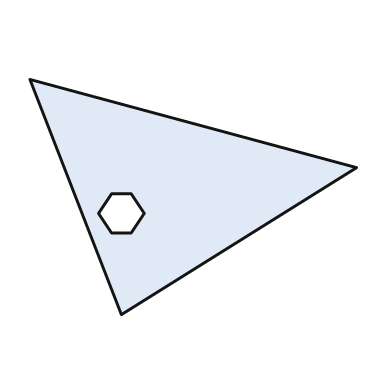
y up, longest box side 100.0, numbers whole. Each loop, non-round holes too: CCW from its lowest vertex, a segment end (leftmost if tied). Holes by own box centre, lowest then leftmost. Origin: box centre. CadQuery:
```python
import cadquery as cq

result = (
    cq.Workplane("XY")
    .moveTo(-22.0, -36.0)
    .lineTo(50.0, 9.0)
    .lineTo(-50.0, 36.0)
    .close()
    .moveTo(-25.0, -11.0)
    .lineTo(-19.0, -11.0)
    .lineTo(-15.0, -5.0)
    .lineTo(-19.0, 1.0)
    .lineTo(-25.0, 1.0)
    .lineTo(-29.0, -5.0)
    .close()
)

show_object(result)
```